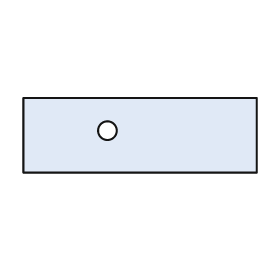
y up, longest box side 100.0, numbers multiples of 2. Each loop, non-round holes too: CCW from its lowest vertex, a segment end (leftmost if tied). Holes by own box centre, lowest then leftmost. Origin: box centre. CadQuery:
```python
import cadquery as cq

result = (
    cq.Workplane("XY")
    .moveTo(-50.0, -16.0)
    .lineTo(50.0, -16.0)
    .lineTo(50.0, 16.0)
    .lineTo(-50.0, 16.0)
    .close()
    .moveTo(-14.0, 2.0)
    .circle(4.0)
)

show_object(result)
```